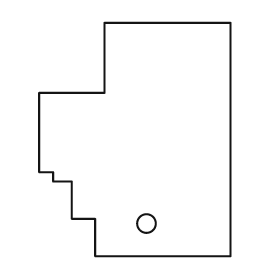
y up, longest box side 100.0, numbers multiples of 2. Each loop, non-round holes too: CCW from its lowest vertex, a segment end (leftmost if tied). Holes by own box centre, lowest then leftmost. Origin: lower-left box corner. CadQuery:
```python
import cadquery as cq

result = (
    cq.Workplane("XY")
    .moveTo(24.0, 0.0)
    .lineTo(82.0, 0.0)
    .lineTo(82.0, 100.0)
    .lineTo(28.0, 100.0)
    .lineTo(28.0, 70.0)
    .lineTo(0.0, 70.0)
    .lineTo(0.0, 36.0)
    .lineTo(6.0, 36.0)
    .lineTo(6.0, 32.0)
    .lineTo(14.0, 32.0)
    .lineTo(14.0, 16.0)
    .lineTo(24.0, 16.0)
    .close()
    .moveTo(46.0, 14.0)
    .circle(4.0)
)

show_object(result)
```